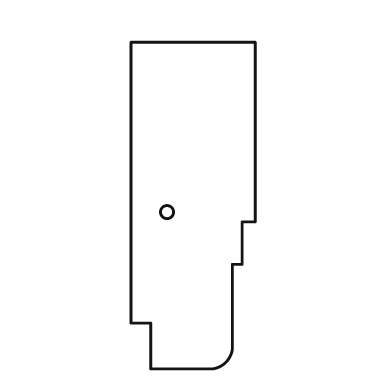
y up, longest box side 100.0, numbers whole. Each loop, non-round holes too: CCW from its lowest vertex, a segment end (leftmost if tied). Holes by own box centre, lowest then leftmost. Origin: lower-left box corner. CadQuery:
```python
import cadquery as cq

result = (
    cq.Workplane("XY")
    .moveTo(6.0, 0.0)
    .lineTo(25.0, 0.0)
    .threePointArc((29.0, 2.0), (31.0, 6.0))
    .lineTo(31.0, 32.0)
    .lineTo(34.0, 32.0)
    .lineTo(34.0, 45.0)
    .lineTo(38.0, 45.0)
    .lineTo(38.0, 100.0)
    .lineTo(0.0, 100.0)
    .lineTo(0.0, 14.0)
    .lineTo(6.0, 14.0)
    .close()
    .moveTo(11.0, 48.0)
    .circle(2.0)
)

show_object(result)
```